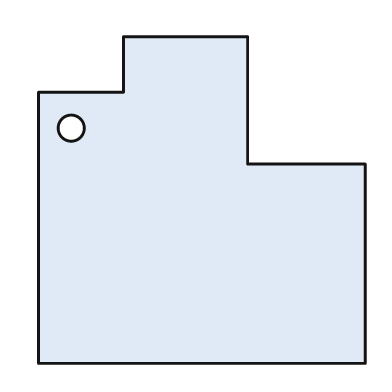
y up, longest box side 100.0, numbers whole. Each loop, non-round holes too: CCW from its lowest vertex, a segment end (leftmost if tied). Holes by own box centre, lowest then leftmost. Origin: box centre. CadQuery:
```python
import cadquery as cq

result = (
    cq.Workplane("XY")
    .moveTo(-50.0, -50.0)
    .lineTo(50.0, -50.0)
    .lineTo(50.0, 11.0)
    .lineTo(14.0, 11.0)
    .lineTo(14.0, 50.0)
    .lineTo(-24.0, 50.0)
    .lineTo(-24.0, 33.0)
    .lineTo(-50.0, 33.0)
    .close()
    .moveTo(-40.0, 22.0)
    .circle(4.0)
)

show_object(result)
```